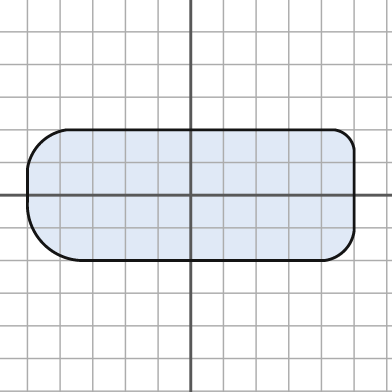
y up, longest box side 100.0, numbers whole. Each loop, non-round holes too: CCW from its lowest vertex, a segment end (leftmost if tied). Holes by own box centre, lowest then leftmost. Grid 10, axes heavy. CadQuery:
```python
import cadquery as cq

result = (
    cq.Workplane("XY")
    .moveTo(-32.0, -20.0)
    .lineTo(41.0, -20.0)
    .threePointArc((47.0, -17.0), (50.0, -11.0))
    .lineTo(50.0, 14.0)
    .threePointArc((48.0, 18.0), (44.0, 20.0))
    .lineTo(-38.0, 20.0)
    .threePointArc((-46.0, 16.0), (-50.0, 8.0))
    .lineTo(-50.0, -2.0)
    .threePointArc((-45.0, -15.0), (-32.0, -20.0))
    .close()
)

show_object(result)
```